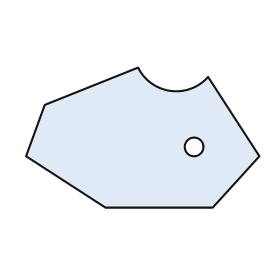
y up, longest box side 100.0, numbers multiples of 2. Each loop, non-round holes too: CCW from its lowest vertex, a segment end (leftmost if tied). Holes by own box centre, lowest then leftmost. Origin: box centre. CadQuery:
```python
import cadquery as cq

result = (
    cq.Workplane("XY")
    .moveTo(-16.0, -30.0)
    .lineTo(30.0, -30.0)
    .lineTo(50.0, -8.0)
    .lineTo(28.0, 26.0)
    .threePointArc((12.0, 20.0), (-2.0, 30.0))
    .lineTo(-42.0, 14.0)
    .lineTo(-50.0, -8.0)
    .close()
    .moveTo(22.0, -4.0)
    .circle(4.0)
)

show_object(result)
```